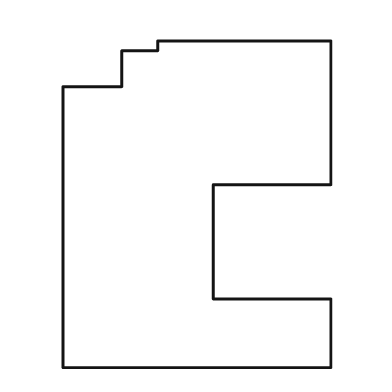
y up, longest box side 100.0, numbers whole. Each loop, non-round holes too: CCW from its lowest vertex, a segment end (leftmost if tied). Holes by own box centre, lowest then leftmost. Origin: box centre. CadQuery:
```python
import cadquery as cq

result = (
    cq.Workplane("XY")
    .moveTo(-41.0, -50.0)
    .lineTo(41.0, -50.0)
    .lineTo(41.0, -29.0)
    .lineTo(5.0, -29.0)
    .lineTo(5.0, 6.0)
    .lineTo(41.0, 6.0)
    .lineTo(41.0, 50.0)
    .lineTo(-12.0, 50.0)
    .lineTo(-12.0, 47.0)
    .lineTo(-23.0, 47.0)
    .lineTo(-23.0, 36.0)
    .lineTo(-41.0, 36.0)
    .close()
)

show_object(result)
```